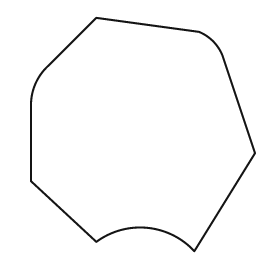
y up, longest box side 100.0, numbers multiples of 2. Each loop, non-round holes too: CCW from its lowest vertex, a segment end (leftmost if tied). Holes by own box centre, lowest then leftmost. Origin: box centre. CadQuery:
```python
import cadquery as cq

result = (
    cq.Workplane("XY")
    .moveTo(22.0, -50.0)
    .lineTo(48.0, -8.0)
    .lineTo(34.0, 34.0)
    .threePointArc((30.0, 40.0), (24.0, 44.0))
    .lineTo(-20.0, 50.0)
    .lineTo(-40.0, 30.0)
    .threePointArc((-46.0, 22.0), (-48.0, 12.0))
    .lineTo(-48.0, -20.0)
    .lineTo(-20.0, -46.0)
    .threePointArc((2.0, -40.0), (22.0, -50.0))
    .close()
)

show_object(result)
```